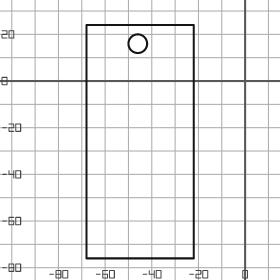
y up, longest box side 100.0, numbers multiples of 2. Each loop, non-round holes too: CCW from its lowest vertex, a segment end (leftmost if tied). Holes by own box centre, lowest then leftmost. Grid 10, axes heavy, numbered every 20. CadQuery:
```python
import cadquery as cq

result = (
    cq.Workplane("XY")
    .moveTo(-68.0, -76.0)
    .lineTo(-22.0, -76.0)
    .lineTo(-22.0, 24.0)
    .lineTo(-68.0, 24.0)
    .close()
    .moveTo(-46.0, 16.0)
    .circle(4.0)
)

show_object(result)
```